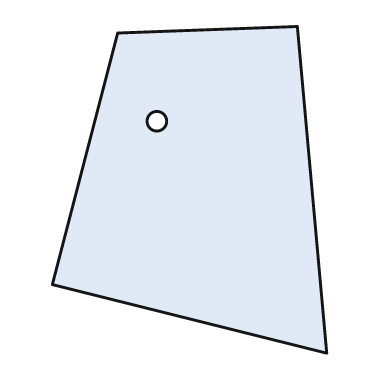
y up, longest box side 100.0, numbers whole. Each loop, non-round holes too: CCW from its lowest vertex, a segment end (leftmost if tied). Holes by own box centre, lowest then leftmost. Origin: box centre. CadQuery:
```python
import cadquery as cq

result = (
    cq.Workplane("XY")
    .moveTo(42.0, -50.0)
    .lineTo(33.0, 50.0)
    .lineTo(-22.0, 48.0)
    .lineTo(-42.0, -29.0)
    .close()
    .moveTo(-10.0, 21.0)
    .circle(3.0)
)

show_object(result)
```